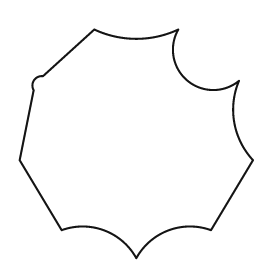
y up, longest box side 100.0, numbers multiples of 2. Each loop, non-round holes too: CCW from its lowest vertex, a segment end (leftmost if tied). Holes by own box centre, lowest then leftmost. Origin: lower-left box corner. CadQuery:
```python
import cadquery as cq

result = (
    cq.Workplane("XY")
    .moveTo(50.0, 0.0)
    .threePointArc((64.0, 12.0), (82.0, 12.0))
    .lineTo(100.0, 42.0)
    .threePointArc((92.0, 58.0), (94.0, 76.0))
    .threePointArc((72.0, 76.0), (68.0, 98.0))
    .threePointArc((50.0, 94.0), (32.0, 98.0))
    .lineTo(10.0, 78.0)
    .threePointArc((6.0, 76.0), (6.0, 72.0))
    .lineTo(0.0, 42.0)
    .lineTo(18.0, 12.0)
    .threePointArc((36.0, 12.0), (50.0, 0.0))
    .close()
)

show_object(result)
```